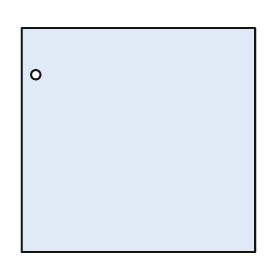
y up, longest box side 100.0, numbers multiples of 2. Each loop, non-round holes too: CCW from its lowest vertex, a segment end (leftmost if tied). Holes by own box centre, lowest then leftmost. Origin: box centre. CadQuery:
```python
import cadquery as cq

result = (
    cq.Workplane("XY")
    .moveTo(-50.0, -48.0)
    .lineTo(50.0, -48.0)
    .lineTo(50.0, 48.0)
    .lineTo(-50.0, 48.0)
    .close()
    .moveTo(-44.0, 28.0)
    .circle(2.0)
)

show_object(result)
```